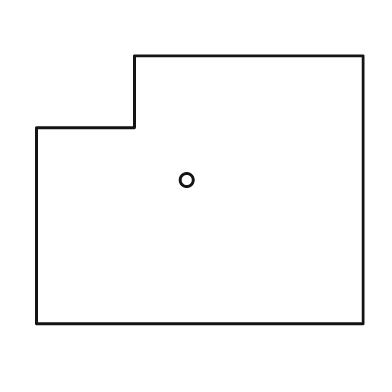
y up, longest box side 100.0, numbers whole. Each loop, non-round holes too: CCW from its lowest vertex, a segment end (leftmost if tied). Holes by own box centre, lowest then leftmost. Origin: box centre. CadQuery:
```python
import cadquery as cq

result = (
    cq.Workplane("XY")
    .moveTo(-50.0, -41.0)
    .lineTo(50.0, -41.0)
    .lineTo(50.0, 41.0)
    .lineTo(-20.0, 41.0)
    .lineTo(-20.0, 19.0)
    .lineTo(-50.0, 19.0)
    .close()
    .moveTo(-4.0, 3.0)
    .circle(2.0)
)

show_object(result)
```